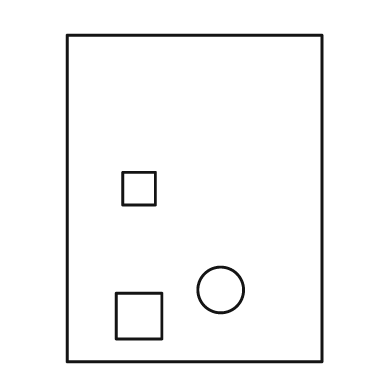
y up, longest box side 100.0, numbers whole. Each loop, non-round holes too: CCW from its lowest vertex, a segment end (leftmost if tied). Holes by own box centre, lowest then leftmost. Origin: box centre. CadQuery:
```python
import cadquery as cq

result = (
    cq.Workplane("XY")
    .moveTo(-39.0, -50.0)
    .lineTo(39.0, -50.0)
    .lineTo(39.0, 50.0)
    .lineTo(-39.0, 50.0)
    .close()
    .moveTo(-24.0, -43.0)
    .lineTo(-10.0, -43.0)
    .lineTo(-10.0, -29.0)
    .lineTo(-24.0, -29.0)
    .close()
    .moveTo(8.0, -28.0)
    .circle(7.0)
    .moveTo(-22.0, -2.0)
    .lineTo(-12.0, -2.0)
    .lineTo(-12.0, 8.0)
    .lineTo(-22.0, 8.0)
    .close()
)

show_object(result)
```